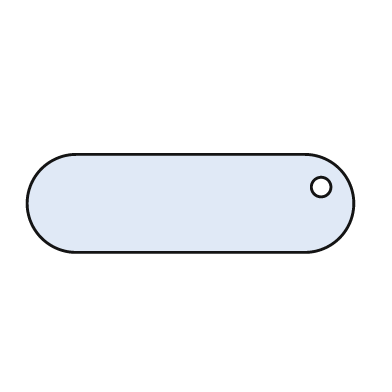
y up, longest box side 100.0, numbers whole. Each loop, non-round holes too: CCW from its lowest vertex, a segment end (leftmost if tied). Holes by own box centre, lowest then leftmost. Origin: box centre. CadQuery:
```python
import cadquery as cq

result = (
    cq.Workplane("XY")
    .moveTo(-35.0, -15.0)
    .lineTo(35.0, -15.0)
    .threePointArc((50.0, 0.0), (35.0, 15.0))
    .lineTo(-35.0, 15.0)
    .threePointArc((-50.0, 0.0), (-35.0, -15.0))
    .close()
    .moveTo(40.0, 5.0)
    .circle(3.0)
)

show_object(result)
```